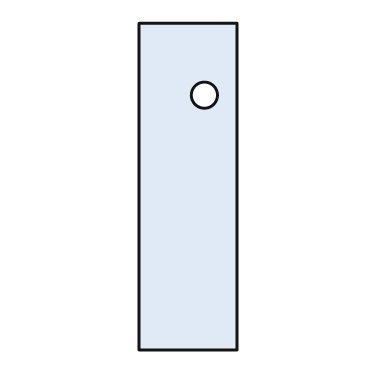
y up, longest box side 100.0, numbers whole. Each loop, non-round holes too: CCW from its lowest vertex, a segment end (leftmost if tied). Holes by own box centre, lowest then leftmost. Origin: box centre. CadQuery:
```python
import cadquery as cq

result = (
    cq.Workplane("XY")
    .moveTo(-15.0, -50.0)
    .lineTo(15.0, -50.0)
    .lineTo(15.0, 50.0)
    .lineTo(-15.0, 50.0)
    .close()
    .moveTo(5.0, 28.0)
    .circle(4.0)
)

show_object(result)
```